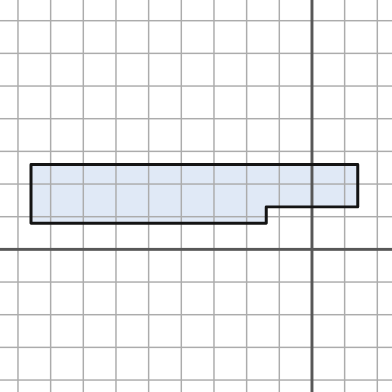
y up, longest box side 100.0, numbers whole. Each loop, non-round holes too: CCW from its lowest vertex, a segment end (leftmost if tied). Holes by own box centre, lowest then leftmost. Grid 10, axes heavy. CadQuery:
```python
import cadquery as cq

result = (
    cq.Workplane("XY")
    .moveTo(-86.0, 8.0)
    .lineTo(-14.0, 8.0)
    .lineTo(-14.0, 13.0)
    .lineTo(14.0, 13.0)
    .lineTo(14.0, 26.0)
    .lineTo(-86.0, 26.0)
    .close()
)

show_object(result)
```